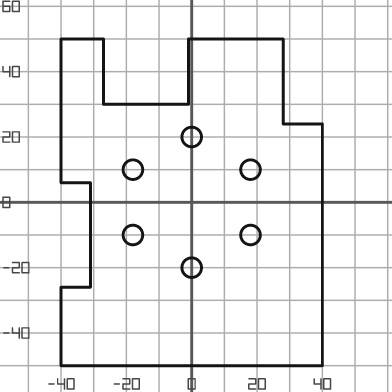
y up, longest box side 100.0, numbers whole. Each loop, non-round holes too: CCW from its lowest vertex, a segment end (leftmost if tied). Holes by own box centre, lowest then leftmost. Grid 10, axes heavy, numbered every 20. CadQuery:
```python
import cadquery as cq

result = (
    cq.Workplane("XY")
    .moveTo(-40.0, -50.0)
    .lineTo(40.0, -50.0)
    .lineTo(40.0, 24.0)
    .lineTo(28.0, 24.0)
    .lineTo(28.0, 50.0)
    .lineTo(-1.0, 50.0)
    .lineTo(-1.0, 30.0)
    .lineTo(-27.0, 30.0)
    .lineTo(-27.0, 50.0)
    .lineTo(-40.0, 50.0)
    .lineTo(-40.0, 6.0)
    .lineTo(-31.0, 6.0)
    .lineTo(-31.0, -26.0)
    .lineTo(-40.0, -26.0)
    .close()
    .moveTo(0.0, -20.0)
    .circle(3.0)
    .moveTo(-18.0, -10.0)
    .circle(3.0)
    .moveTo(18.0, -10.0)
    .circle(3.0)
    .moveTo(-18.0, 10.0)
    .circle(3.0)
    .moveTo(18.0, 10.0)
    .circle(3.0)
    .moveTo(0.0, 20.0)
    .circle(3.0)
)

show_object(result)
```